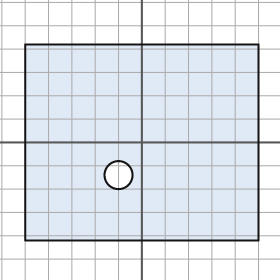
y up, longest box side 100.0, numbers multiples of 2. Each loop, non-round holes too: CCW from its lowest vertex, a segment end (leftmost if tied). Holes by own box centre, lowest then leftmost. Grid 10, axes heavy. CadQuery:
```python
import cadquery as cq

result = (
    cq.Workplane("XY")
    .moveTo(-50.0, -42.0)
    .lineTo(50.0, -42.0)
    .lineTo(50.0, 42.0)
    .lineTo(-50.0, 42.0)
    .close()
    .moveTo(-10.0, -14.0)
    .circle(6.0)
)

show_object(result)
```